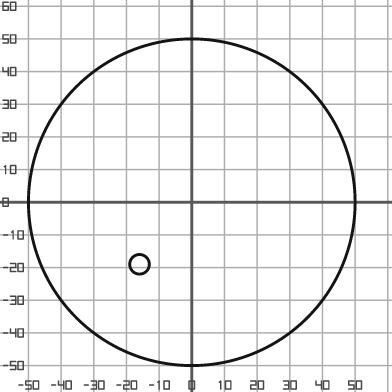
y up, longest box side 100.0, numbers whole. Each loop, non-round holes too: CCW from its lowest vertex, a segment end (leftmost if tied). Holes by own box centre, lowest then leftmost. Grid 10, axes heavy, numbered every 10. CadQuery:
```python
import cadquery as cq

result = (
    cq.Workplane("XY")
    .moveTo(0.0, 0.0)
    .circle(50.0)
    .moveTo(-16.0, -19.0)
    .circle(3.0)
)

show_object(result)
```